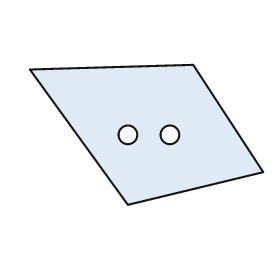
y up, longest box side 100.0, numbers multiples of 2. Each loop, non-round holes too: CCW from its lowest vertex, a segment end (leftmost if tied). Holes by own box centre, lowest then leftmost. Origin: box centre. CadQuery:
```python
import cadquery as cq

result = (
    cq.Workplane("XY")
    .moveTo(-8.0, -30.0)
    .lineTo(50.0, -16.0)
    .lineTo(20.0, 30.0)
    .lineTo(-50.0, 28.0)
    .close()
    .moveTo(-8.0, 0.0)
    .circle(4.0)
    .moveTo(10.0, 0.0)
    .circle(4.0)
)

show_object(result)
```